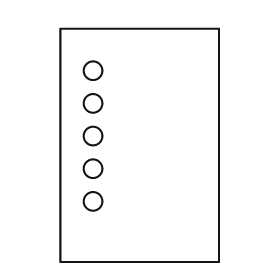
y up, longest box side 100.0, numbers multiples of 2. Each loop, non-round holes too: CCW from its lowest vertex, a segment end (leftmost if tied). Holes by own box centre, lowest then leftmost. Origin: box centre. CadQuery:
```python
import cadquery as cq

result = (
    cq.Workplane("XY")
    .moveTo(-34.0, -50.0)
    .lineTo(34.0, -50.0)
    .lineTo(34.0, 50.0)
    .lineTo(-34.0, 50.0)
    .close()
    .moveTo(-20.0, -24.0)
    .circle(4.0)
    .moveTo(-20.0, -10.0)
    .circle(4.0)
    .moveTo(-20.0, 4.0)
    .circle(4.0)
    .moveTo(-20.0, 18.0)
    .circle(4.0)
    .moveTo(-20.0, 32.0)
    .circle(4.0)
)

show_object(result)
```